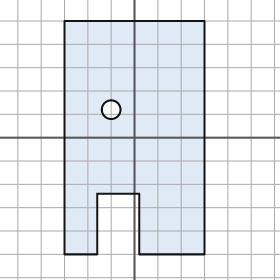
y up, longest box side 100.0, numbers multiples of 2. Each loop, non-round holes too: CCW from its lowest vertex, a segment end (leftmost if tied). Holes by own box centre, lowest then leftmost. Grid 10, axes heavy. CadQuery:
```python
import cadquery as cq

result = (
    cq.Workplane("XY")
    .moveTo(-30.0, -50.0)
    .lineTo(-16.0, -50.0)
    .lineTo(-16.0, -24.0)
    .lineTo(2.0, -24.0)
    .lineTo(2.0, -50.0)
    .lineTo(30.0, -50.0)
    .lineTo(30.0, 50.0)
    .lineTo(-30.0, 50.0)
    .close()
    .moveTo(-10.0, 12.0)
    .circle(4.0)
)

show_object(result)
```